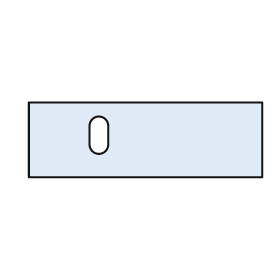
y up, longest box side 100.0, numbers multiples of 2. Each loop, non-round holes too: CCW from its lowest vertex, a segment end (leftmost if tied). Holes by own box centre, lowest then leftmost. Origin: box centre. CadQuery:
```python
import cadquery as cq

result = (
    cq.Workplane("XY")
    .moveTo(-50.0, -16.0)
    .lineTo(50.0, -16.0)
    .lineTo(50.0, 16.0)
    .lineTo(-50.0, 16.0)
    .close()
    .moveTo(-24.0, -2.0)
    .threePointArc((-20.0, -6.0), (-16.0, -2.0))
    .lineTo(-16.0, 6.0)
    .threePointArc((-20.0, 10.0), (-24.0, 6.0))
    .close()
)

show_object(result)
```